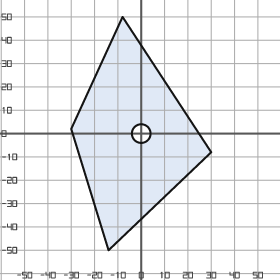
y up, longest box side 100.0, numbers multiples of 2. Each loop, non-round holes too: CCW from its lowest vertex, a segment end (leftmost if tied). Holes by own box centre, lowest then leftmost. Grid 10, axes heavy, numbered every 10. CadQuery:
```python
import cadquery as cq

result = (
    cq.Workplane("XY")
    .moveTo(-14.0, -50.0)
    .lineTo(30.0, -8.0)
    .lineTo(-8.0, 50.0)
    .lineTo(-30.0, 2.0)
    .close()
    .moveTo(0.0, 0.0)
    .circle(4.0)
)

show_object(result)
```